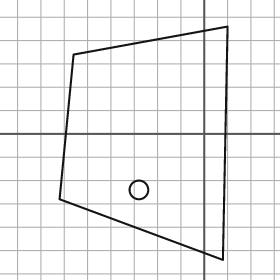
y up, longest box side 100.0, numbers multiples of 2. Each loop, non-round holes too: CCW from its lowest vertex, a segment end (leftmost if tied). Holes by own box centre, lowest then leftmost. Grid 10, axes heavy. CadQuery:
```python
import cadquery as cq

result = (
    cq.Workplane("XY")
    .moveTo(8.0, -54.0)
    .lineTo(10.0, 46.0)
    .lineTo(-56.0, 34.0)
    .lineTo(-62.0, -28.0)
    .close()
    .moveTo(-28.0, -24.0)
    .circle(4.0)
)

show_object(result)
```